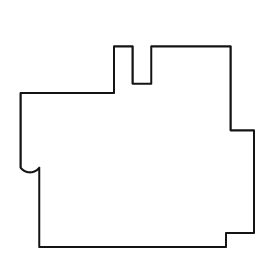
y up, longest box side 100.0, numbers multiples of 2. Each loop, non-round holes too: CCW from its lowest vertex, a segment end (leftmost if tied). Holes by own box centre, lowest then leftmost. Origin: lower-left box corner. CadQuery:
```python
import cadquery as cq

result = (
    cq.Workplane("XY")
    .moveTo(8.0, 0.0)
    .lineTo(88.0, 0.0)
    .lineTo(88.0, 6.0)
    .lineTo(100.0, 6.0)
    .lineTo(100.0, 50.0)
    .lineTo(90.0, 50.0)
    .lineTo(90.0, 86.0)
    .lineTo(56.0, 86.0)
    .lineTo(56.0, 70.0)
    .lineTo(48.0, 70.0)
    .lineTo(48.0, 86.0)
    .lineTo(40.0, 86.0)
    .lineTo(40.0, 66.0)
    .lineTo(0.0, 66.0)
    .lineTo(0.0, 34.0)
    .threePointArc((4.0, 32.0), (8.0, 34.0))
    .close()
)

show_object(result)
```